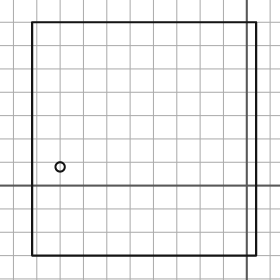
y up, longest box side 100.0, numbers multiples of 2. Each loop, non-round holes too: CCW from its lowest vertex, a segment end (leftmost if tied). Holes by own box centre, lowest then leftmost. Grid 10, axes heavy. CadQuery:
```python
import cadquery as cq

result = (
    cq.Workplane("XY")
    .moveTo(-92.0, -30.0)
    .lineTo(4.0, -30.0)
    .lineTo(4.0, 70.0)
    .lineTo(-92.0, 70.0)
    .close()
    .moveTo(-80.0, 8.0)
    .circle(2.0)
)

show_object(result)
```